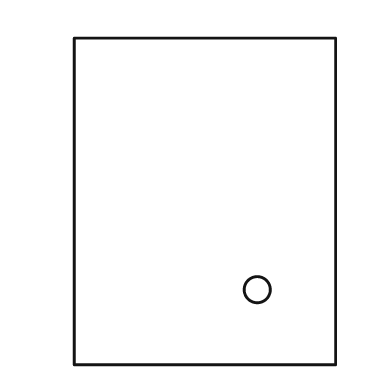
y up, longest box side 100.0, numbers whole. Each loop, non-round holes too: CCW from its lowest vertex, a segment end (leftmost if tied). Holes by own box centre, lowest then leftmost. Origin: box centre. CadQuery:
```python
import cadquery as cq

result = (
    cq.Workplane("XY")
    .moveTo(-40.0, -50.0)
    .lineTo(40.0, -50.0)
    .lineTo(40.0, 50.0)
    .lineTo(-40.0, 50.0)
    .close()
    .moveTo(16.0, -27.0)
    .circle(4.0)
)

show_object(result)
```